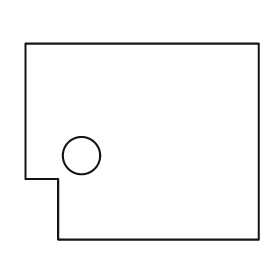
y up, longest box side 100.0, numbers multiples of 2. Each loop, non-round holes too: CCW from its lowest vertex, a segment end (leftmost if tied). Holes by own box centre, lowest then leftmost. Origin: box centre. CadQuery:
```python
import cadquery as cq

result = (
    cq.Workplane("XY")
    .moveTo(-36.0, -42.0)
    .lineTo(50.0, -42.0)
    .lineTo(50.0, 42.0)
    .lineTo(-50.0, 42.0)
    .lineTo(-50.0, -16.0)
    .lineTo(-36.0, -16.0)
    .close()
    .moveTo(-26.0, -6.0)
    .circle(8.0)
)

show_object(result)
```